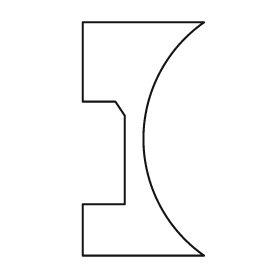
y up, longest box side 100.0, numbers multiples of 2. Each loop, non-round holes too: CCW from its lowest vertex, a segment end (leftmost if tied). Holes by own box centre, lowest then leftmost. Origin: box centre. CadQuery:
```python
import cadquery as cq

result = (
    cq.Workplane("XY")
    .moveTo(-26.0, -50.0)
    .lineTo(26.0, -50.0)
    .threePointArc((0.0, 0.0), (26.0, 50.0))
    .lineTo(-26.0, 50.0)
    .lineTo(-26.0, 16.0)
    .lineTo(-12.0, 16.0)
    .lineTo(-8.0, 10.0)
    .lineTo(-8.0, -28.0)
    .lineTo(-26.0, -28.0)
    .close()
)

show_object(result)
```